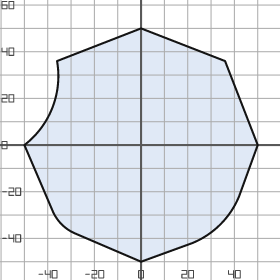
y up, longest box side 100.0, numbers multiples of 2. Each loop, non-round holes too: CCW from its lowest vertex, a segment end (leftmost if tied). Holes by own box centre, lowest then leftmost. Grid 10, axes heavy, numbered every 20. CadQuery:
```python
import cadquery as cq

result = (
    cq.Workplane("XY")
    .moveTo(0.0, -50.0)
    .lineTo(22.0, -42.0)
    .threePointArc((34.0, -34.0), (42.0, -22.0))
    .lineTo(50.0, 0.0)
    .lineTo(36.0, 36.0)
    .lineTo(0.0, 50.0)
    .lineTo(-36.0, 36.0)
    .threePointArc((-38.0, 16.0), (-50.0, 0.0))
    .lineTo(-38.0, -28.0)
    .threePointArc((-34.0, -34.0), (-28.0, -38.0))
    .close()
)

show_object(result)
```